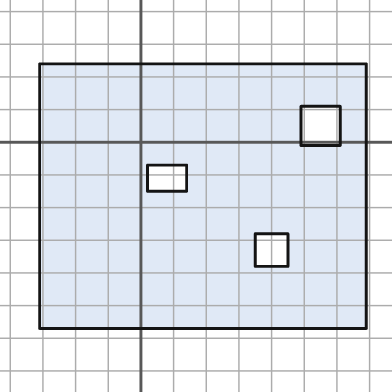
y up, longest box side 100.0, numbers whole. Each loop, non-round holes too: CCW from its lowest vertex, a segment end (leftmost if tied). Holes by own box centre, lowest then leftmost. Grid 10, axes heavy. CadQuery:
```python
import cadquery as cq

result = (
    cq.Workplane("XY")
    .moveTo(-31.0, -57.0)
    .lineTo(69.0, -57.0)
    .lineTo(69.0, 24.0)
    .lineTo(-31.0, 24.0)
    .close()
    .moveTo(35.0, -38.0)
    .lineTo(45.0, -38.0)
    .lineTo(45.0, -28.0)
    .lineTo(35.0, -28.0)
    .close()
    .moveTo(2.0, -15.0)
    .lineTo(14.0, -15.0)
    .lineTo(14.0, -7.0)
    .lineTo(2.0, -7.0)
    .close()
    .moveTo(49.0, -1.0)
    .lineTo(61.0, -1.0)
    .lineTo(61.0, 11.0)
    .lineTo(49.0, 11.0)
    .close()
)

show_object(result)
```